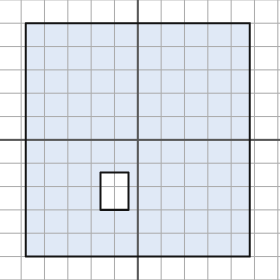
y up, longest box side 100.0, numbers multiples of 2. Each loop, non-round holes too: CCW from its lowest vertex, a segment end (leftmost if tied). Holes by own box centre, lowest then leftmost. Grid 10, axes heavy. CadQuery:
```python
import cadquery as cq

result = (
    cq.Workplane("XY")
    .moveTo(-48.0, -50.0)
    .lineTo(48.0, -50.0)
    .lineTo(48.0, 50.0)
    .lineTo(-48.0, 50.0)
    .close()
    .moveTo(-16.0, -30.0)
    .lineTo(-4.0, -30.0)
    .lineTo(-4.0, -14.0)
    .lineTo(-16.0, -14.0)
    .close()
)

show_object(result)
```